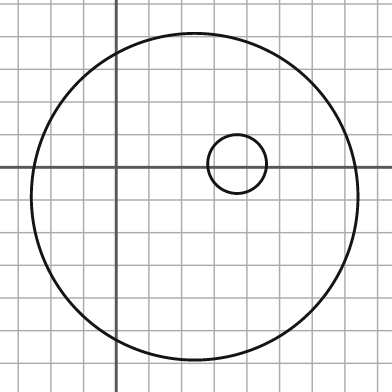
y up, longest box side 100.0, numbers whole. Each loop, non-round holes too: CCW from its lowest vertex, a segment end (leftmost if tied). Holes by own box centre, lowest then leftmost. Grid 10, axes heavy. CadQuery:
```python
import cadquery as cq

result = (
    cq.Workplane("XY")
    .moveTo(24.0, -9.0)
    .circle(50.0)
    .moveTo(37.0, 1.0)
    .circle(9.0)
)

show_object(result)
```